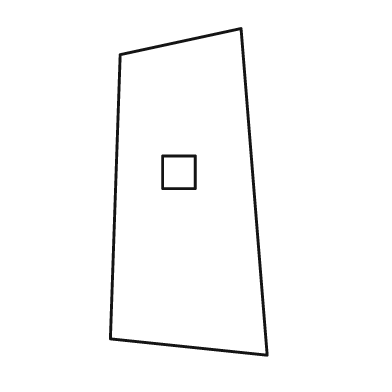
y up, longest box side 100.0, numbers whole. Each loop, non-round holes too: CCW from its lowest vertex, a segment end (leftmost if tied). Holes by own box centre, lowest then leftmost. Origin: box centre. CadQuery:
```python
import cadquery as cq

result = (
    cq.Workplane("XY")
    .moveTo(24.0, -50.0)
    .lineTo(16.0, 50.0)
    .lineTo(-21.0, 42.0)
    .lineTo(-24.0, -45.0)
    .close()
    .moveTo(-8.0, 1.0)
    .lineTo(2.0, 1.0)
    .lineTo(2.0, 11.0)
    .lineTo(-8.0, 11.0)
    .close()
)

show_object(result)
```